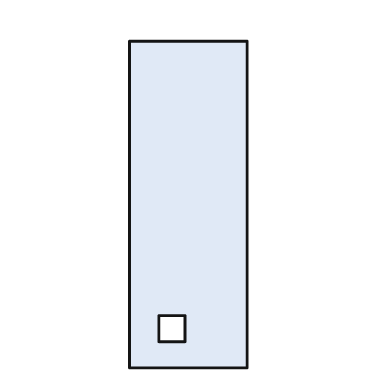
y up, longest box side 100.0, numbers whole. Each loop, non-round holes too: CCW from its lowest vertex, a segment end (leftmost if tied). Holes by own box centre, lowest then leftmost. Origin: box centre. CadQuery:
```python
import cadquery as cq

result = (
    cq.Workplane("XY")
    .moveTo(-18.0, -50.0)
    .lineTo(18.0, -50.0)
    .lineTo(18.0, 50.0)
    .lineTo(-18.0, 50.0)
    .close()
    .moveTo(-9.0, -42.0)
    .lineTo(-1.0, -42.0)
    .lineTo(-1.0, -34.0)
    .lineTo(-9.0, -34.0)
    .close()
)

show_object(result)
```